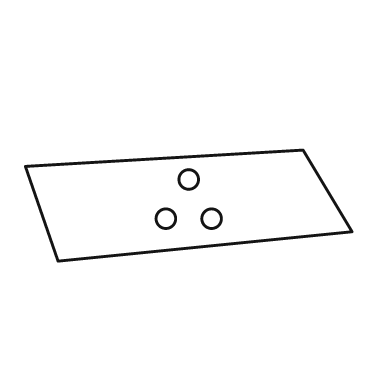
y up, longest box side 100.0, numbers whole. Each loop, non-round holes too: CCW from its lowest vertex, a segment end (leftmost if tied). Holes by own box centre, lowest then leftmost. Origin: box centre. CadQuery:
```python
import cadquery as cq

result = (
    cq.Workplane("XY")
    .moveTo(-40.0, -17.0)
    .lineTo(50.0, -8.0)
    .lineTo(35.0, 17.0)
    .lineTo(-50.0, 12.0)
    .close()
    .moveTo(-7.0, -4.0)
    .circle(3.0)
    .moveTo(7.0, -4.0)
    .circle(3.0)
    .moveTo(0.0, 8.0)
    .circle(3.0)
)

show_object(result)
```